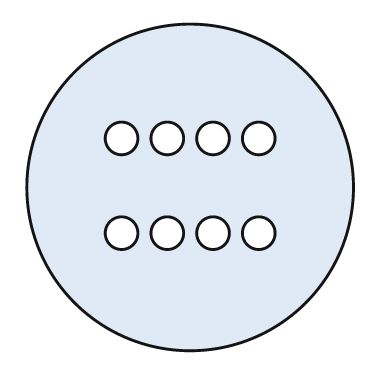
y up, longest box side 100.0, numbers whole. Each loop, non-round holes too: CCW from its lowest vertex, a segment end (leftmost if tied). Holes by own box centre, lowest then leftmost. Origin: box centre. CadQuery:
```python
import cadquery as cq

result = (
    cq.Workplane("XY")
    .moveTo(0.0, 0.0)
    .circle(50.0)
    .moveTo(-21.0, -14.0)
    .circle(5.0)
    .moveTo(-7.0, -14.0)
    .circle(5.0)
    .moveTo(7.0, -14.0)
    .circle(5.0)
    .moveTo(21.0, -14.0)
    .circle(5.0)
    .moveTo(-21.0, 15.0)
    .circle(5.0)
    .moveTo(-7.0, 15.0)
    .circle(5.0)
    .moveTo(7.0, 15.0)
    .circle(5.0)
    .moveTo(21.0, 15.0)
    .circle(5.0)
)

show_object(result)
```